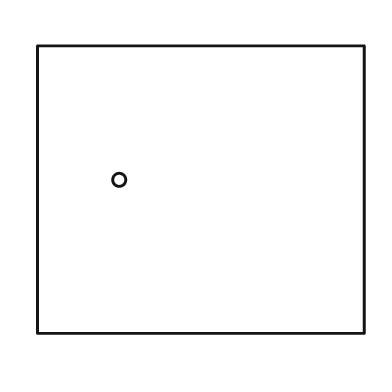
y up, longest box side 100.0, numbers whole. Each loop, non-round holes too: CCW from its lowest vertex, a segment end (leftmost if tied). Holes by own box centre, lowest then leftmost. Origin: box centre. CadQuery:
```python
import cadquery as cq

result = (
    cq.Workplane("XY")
    .moveTo(-50.0, -44.0)
    .lineTo(50.0, -44.0)
    .lineTo(50.0, 44.0)
    .lineTo(-50.0, 44.0)
    .close()
    .moveTo(-25.0, 3.0)
    .circle(2.0)
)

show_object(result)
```